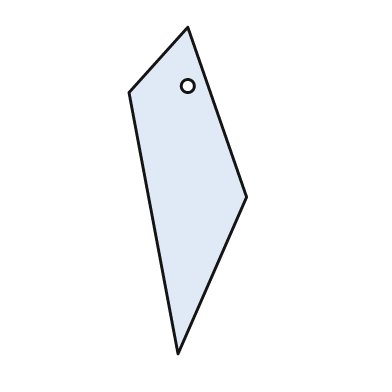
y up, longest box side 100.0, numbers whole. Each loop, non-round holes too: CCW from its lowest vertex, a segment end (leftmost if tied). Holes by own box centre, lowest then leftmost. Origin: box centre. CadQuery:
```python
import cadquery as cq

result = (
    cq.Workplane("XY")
    .moveTo(-3.0, -50.0)
    .lineTo(18.0, -2.0)
    .lineTo(0.0, 50.0)
    .lineTo(-18.0, 30.0)
    .close()
    .moveTo(0.0, 32.0)
    .circle(2.0)
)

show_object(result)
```